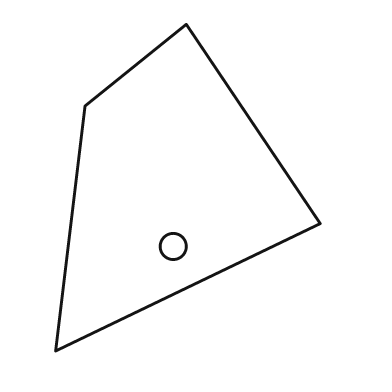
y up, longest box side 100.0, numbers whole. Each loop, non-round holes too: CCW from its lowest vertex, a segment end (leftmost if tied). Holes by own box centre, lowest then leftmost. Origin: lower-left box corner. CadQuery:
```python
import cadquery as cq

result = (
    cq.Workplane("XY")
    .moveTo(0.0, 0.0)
    .lineTo(81.0, 39.0)
    .lineTo(40.0, 100.0)
    .lineTo(9.0, 75.0)
    .close()
    .moveTo(36.0, 32.0)
    .circle(4.0)
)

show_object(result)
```